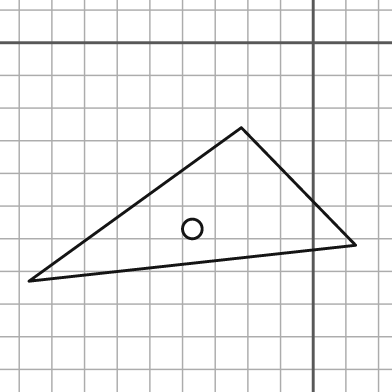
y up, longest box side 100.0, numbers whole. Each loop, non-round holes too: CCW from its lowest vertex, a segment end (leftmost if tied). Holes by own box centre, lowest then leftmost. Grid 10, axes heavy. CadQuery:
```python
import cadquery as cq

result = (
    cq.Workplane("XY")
    .moveTo(-87.0, -73.0)
    .lineTo(13.0, -62.0)
    .lineTo(-22.0, -26.0)
    .close()
    .moveTo(-37.0, -57.0)
    .circle(3.0)
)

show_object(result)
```